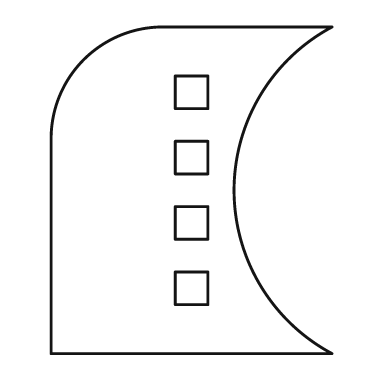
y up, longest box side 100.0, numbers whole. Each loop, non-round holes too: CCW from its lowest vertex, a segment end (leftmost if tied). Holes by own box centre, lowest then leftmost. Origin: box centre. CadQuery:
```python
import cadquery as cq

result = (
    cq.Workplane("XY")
    .moveTo(-43.0, -50.0)
    .lineTo(43.0, -50.0)
    .threePointArc((13.0, 0.0), (43.0, 50.0))
    .lineTo(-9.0, 50.0)
    .threePointArc((-33.0, 40.0), (-43.0, 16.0))
    .close()
    .moveTo(-5.0, -35.0)
    .lineTo(5.0, -35.0)
    .lineTo(5.0, -25.0)
    .lineTo(-5.0, -25.0)
    .close()
    .moveTo(-5.0, -15.0)
    .lineTo(5.0, -15.0)
    .lineTo(5.0, -5.0)
    .lineTo(-5.0, -5.0)
    .close()
    .moveTo(-5.0, 5.0)
    .lineTo(5.0, 5.0)
    .lineTo(5.0, 15.0)
    .lineTo(-5.0, 15.0)
    .close()
    .moveTo(-5.0, 25.0)
    .lineTo(5.0, 25.0)
    .lineTo(5.0, 35.0)
    .lineTo(-5.0, 35.0)
    .close()
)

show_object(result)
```